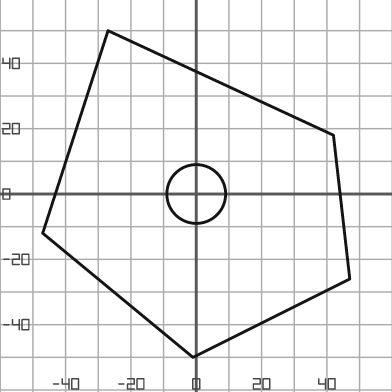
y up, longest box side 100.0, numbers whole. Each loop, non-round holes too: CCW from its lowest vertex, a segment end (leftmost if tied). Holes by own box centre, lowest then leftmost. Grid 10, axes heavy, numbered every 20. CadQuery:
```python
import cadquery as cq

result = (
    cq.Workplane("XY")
    .moveTo(-1.0, -50.0)
    .lineTo(47.0, -26.0)
    .lineTo(42.0, 18.0)
    .lineTo(-27.0, 50.0)
    .lineTo(-47.0, -12.0)
    .close()
    .moveTo(0.0, 0.0)
    .circle(9.0)
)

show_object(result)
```